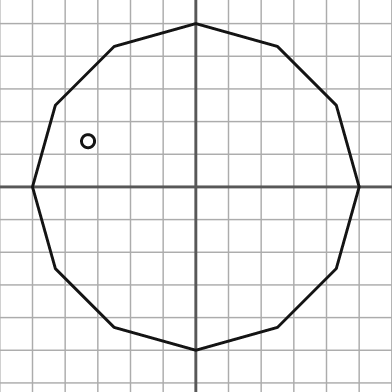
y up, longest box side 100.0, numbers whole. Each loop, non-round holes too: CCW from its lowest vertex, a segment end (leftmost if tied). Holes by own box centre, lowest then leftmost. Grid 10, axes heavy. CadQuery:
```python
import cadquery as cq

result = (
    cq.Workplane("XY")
    .moveTo(0.0, -50.0)
    .lineTo(25.0, -43.0)
    .lineTo(43.0, -25.0)
    .lineTo(50.0, 0.0)
    .lineTo(43.0, 25.0)
    .lineTo(25.0, 43.0)
    .lineTo(0.0, 50.0)
    .lineTo(-25.0, 43.0)
    .lineTo(-43.0, 25.0)
    .lineTo(-50.0, 0.0)
    .lineTo(-43.0, -25.0)
    .lineTo(-25.0, -43.0)
    .close()
    .moveTo(-33.0, 14.0)
    .circle(2.0)
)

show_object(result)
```